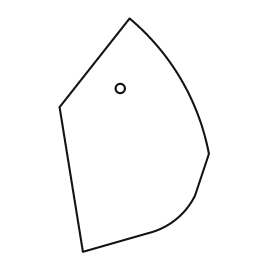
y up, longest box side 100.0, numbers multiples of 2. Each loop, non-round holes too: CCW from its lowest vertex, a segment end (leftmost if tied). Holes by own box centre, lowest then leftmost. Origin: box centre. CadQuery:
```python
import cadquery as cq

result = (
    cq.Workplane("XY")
    .moveTo(-22.0, -50.0)
    .lineTo(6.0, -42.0)
    .threePointArc((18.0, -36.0), (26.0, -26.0))
    .lineTo(32.0, -8.0)
    .threePointArc((20.0, 24.0), (-2.0, 50.0))
    .lineTo(-32.0, 12.0)
    .close()
    .moveTo(-6.0, 20.0)
    .circle(2.0)
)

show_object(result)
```